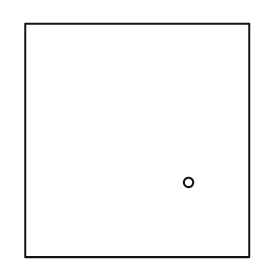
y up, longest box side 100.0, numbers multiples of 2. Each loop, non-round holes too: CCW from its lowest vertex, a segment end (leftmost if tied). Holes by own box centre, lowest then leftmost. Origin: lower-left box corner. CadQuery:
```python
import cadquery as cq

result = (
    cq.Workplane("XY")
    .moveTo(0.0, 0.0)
    .lineTo(96.0, 0.0)
    .lineTo(96.0, 100.0)
    .lineTo(0.0, 100.0)
    .close()
    .moveTo(70.0, 32.0)
    .circle(2.0)
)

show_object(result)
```